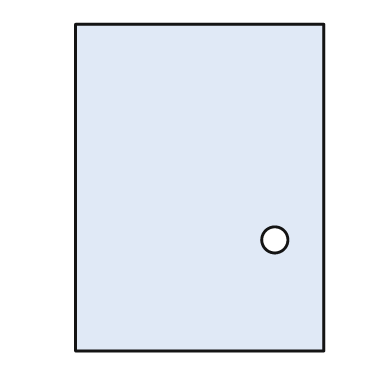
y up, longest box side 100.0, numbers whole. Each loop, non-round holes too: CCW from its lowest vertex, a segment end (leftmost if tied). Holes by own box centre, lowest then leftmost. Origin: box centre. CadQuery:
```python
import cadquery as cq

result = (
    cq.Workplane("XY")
    .moveTo(-38.0, -50.0)
    .lineTo(38.0, -50.0)
    .lineTo(38.0, 50.0)
    .lineTo(-38.0, 50.0)
    .close()
    .moveTo(23.0, -16.0)
    .circle(4.0)
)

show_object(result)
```